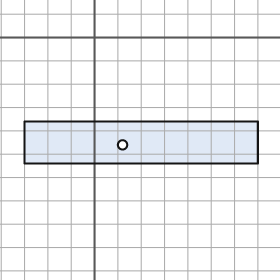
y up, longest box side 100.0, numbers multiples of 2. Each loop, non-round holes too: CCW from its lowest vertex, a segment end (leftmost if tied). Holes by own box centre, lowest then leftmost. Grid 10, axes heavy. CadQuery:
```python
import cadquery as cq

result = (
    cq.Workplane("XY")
    .moveTo(-30.0, -54.0)
    .lineTo(70.0, -54.0)
    .lineTo(70.0, -36.0)
    .lineTo(-30.0, -36.0)
    .close()
    .moveTo(12.0, -46.0)
    .circle(2.0)
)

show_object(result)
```